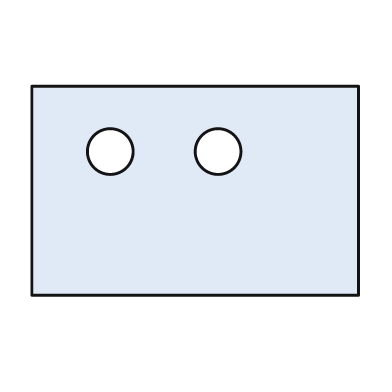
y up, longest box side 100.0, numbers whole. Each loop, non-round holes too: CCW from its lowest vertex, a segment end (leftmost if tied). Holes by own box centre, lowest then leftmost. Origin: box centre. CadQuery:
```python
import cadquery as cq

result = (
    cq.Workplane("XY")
    .moveTo(-50.0, -32.0)
    .lineTo(50.0, -32.0)
    .lineTo(50.0, 32.0)
    .lineTo(-50.0, 32.0)
    .close()
    .moveTo(-26.0, 12.0)
    .circle(7.0)
    .moveTo(7.0, 12.0)
    .circle(7.0)
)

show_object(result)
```